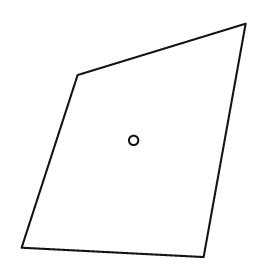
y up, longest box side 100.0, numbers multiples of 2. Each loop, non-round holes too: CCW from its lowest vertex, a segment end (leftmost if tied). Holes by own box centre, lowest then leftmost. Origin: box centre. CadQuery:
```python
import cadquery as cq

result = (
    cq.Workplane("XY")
    .moveTo(30.0, -50.0)
    .lineTo(48.0, 50.0)
    .lineTo(-24.0, 28.0)
    .lineTo(-48.0, -46.0)
    .close()
    .moveTo(0.0, 0.0)
    .circle(2.0)
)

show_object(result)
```